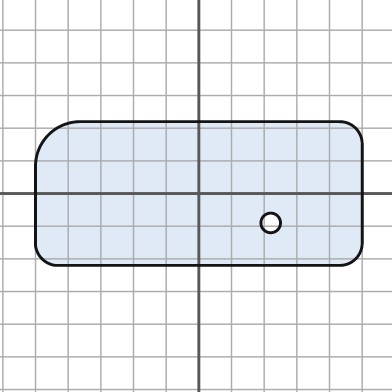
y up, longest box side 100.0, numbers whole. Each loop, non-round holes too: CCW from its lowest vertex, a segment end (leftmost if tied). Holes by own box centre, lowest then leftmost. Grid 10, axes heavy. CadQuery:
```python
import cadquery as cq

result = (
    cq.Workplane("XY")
    .moveTo(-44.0, -22.0)
    .lineTo(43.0, -22.0)
    .threePointArc((48.0, -20.0), (50.0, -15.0))
    .lineTo(50.0, 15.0)
    .threePointArc((48.0, 20.0), (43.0, 22.0))
    .lineTo(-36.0, 22.0)
    .threePointArc((-46.0, 18.0), (-50.0, 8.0))
    .lineTo(-50.0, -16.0)
    .threePointArc((-48.0, -20.0), (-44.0, -22.0))
    .close()
    .moveTo(22.0, -9.0)
    .circle(3.0)
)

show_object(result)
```